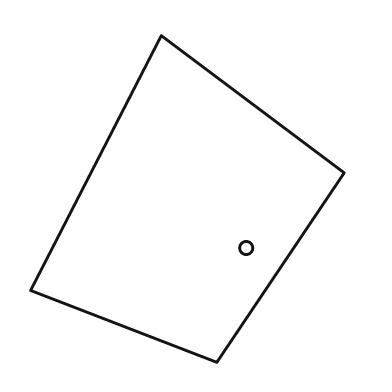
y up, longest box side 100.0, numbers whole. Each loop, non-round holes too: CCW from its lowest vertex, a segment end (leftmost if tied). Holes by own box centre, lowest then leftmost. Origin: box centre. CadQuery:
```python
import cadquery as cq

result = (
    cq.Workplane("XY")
    .moveTo(9.0, -50.0)
    .lineTo(48.0, 8.0)
    .lineTo(-8.0, 50.0)
    .lineTo(-48.0, -28.0)
    .close()
    .moveTo(18.0, -15.0)
    .circle(2.0)
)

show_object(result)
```